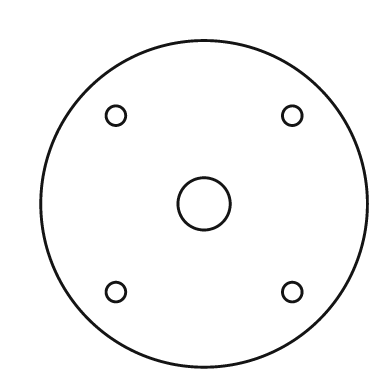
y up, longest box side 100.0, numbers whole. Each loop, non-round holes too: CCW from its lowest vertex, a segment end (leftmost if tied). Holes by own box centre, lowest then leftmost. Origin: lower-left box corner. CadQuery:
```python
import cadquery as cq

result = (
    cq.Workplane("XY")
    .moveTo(50.0, 50.0)
    .circle(50.0)
    .moveTo(23.0, 23.0)
    .circle(3.0)
    .moveTo(77.0, 23.0)
    .circle(3.0)
    .moveTo(50.0, 50.0)
    .circle(8.0)
    .moveTo(23.0, 77.0)
    .circle(3.0)
    .moveTo(77.0, 77.0)
    .circle(3.0)
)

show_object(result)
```